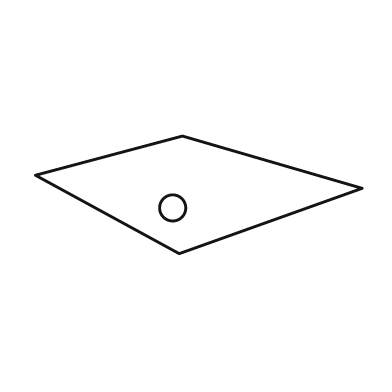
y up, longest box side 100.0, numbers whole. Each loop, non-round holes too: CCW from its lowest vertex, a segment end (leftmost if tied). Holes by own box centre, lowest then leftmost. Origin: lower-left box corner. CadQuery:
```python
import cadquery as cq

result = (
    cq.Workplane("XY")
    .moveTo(44.0, 0.0)
    .lineTo(100.0, 20.0)
    .lineTo(45.0, 36.0)
    .lineTo(0.0, 24.0)
    .close()
    .moveTo(42.0, 14.0)
    .circle(4.0)
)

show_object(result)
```